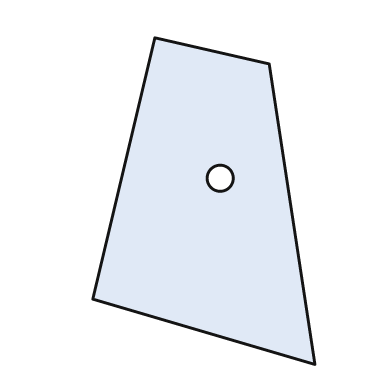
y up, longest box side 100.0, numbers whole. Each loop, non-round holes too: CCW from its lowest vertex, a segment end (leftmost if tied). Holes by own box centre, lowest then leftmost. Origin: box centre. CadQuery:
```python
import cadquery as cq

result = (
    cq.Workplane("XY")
    .moveTo(34.0, -50.0)
    .lineTo(20.0, 42.0)
    .lineTo(-15.0, 50.0)
    .lineTo(-34.0, -30.0)
    .close()
    .moveTo(5.0, 7.0)
    .circle(4.0)
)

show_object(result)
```